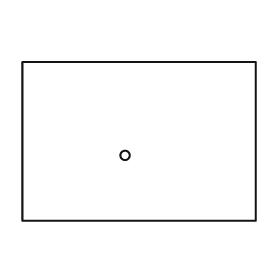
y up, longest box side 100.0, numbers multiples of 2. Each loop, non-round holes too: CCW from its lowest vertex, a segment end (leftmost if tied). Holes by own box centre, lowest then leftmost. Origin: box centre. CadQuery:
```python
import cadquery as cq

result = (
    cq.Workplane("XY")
    .moveTo(-50.0, -34.0)
    .lineTo(50.0, -34.0)
    .lineTo(50.0, 34.0)
    .lineTo(-50.0, 34.0)
    .close()
    .moveTo(-6.0, -6.0)
    .circle(2.0)
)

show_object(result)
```